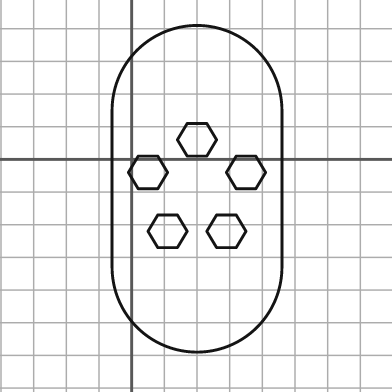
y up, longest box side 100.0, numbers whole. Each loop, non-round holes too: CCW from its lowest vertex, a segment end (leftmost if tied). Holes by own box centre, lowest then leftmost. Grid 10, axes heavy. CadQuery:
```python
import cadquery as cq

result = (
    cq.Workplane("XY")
    .moveTo(-6.0, -33.0)
    .threePointArc((20.0, -59.0), (46.0, -33.0))
    .lineTo(46.0, 15.0)
    .threePointArc((20.0, 41.0), (-6.0, 15.0))
    .close()
    .moveTo(8.0, -27.0)
    .lineTo(14.0, -27.0)
    .lineTo(17.0, -22.0)
    .lineTo(14.0, -17.0)
    .lineTo(8.0, -17.0)
    .lineTo(5.0, -22.0)
    .close()
    .moveTo(26.0, -27.0)
    .lineTo(32.0, -27.0)
    .lineTo(35.0, -22.0)
    .lineTo(32.0, -17.0)
    .lineTo(26.0, -17.0)
    .lineTo(23.0, -22.0)
    .close()
    .moveTo(2.0, -9.0)
    .lineTo(8.0, -9.0)
    .lineTo(11.0, -4.0)
    .lineTo(8.0, 1.0)
    .lineTo(2.0, 1.0)
    .lineTo(-1.0, -4.0)
    .close()
    .moveTo(32.0, -9.0)
    .lineTo(38.0, -9.0)
    .lineTo(41.0, -4.0)
    .lineTo(38.0, 1.0)
    .lineTo(32.0, 1.0)
    .lineTo(29.0, -4.0)
    .close()
    .moveTo(17.0, 1.0)
    .lineTo(23.0, 1.0)
    .lineTo(26.0, 6.0)
    .lineTo(23.0, 11.0)
    .lineTo(17.0, 11.0)
    .lineTo(14.0, 6.0)
    .close()
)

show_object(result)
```